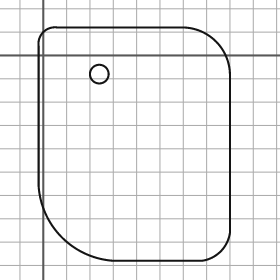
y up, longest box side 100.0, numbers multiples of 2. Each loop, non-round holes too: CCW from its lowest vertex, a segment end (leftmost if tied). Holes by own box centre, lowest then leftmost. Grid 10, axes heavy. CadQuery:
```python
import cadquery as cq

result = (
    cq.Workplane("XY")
    .moveTo(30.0, -88.0)
    .lineTo(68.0, -88.0)
    .threePointArc((76.0, -84.0), (80.0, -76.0))
    .lineTo(80.0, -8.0)
    .threePointArc((74.0, 6.0), (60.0, 12.0))
    .lineTo(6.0, 12.0)
    .threePointArc((0.0, 10.0), (-2.0, 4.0))
    .lineTo(-2.0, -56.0)
    .threePointArc((8.0, -78.0), (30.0, -88.0))
    .close()
    .moveTo(24.0, -8.0)
    .circle(4.0)
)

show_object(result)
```